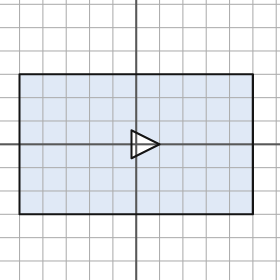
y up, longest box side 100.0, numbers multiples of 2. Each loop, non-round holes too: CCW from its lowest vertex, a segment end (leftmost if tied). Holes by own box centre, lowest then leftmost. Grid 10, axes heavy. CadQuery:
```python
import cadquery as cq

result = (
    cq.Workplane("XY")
    .moveTo(-50.0, -30.0)
    .lineTo(50.0, -30.0)
    .lineTo(50.0, 30.0)
    .lineTo(-50.0, 30.0)
    .close()
    .moveTo(-2.0, -6.0)
    .lineTo(10.0, 0.0)
    .lineTo(-2.0, 6.0)
    .close()
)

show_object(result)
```